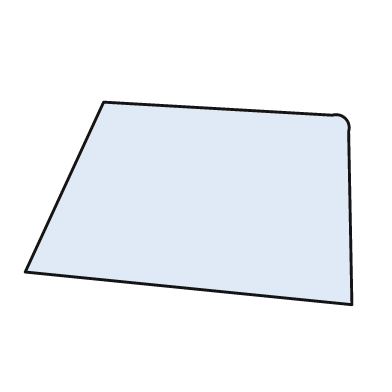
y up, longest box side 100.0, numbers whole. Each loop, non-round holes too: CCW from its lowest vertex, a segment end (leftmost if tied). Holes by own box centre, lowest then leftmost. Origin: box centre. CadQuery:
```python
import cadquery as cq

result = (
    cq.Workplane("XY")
    .moveTo(50.0, -31.0)
    .lineTo(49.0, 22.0)
    .threePointArc((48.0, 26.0), (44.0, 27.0))
    .lineTo(-26.0, 31.0)
    .lineTo(-50.0, -21.0)
    .close()
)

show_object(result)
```